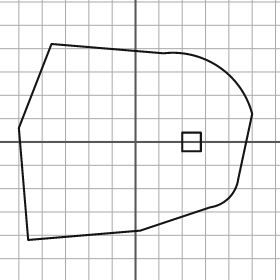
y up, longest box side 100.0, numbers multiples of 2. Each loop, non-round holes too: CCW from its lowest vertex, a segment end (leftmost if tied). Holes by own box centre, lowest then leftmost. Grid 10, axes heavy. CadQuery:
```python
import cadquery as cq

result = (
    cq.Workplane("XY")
    .moveTo(-46.0, -42.0)
    .lineTo(2.0, -38.0)
    .lineTo(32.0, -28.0)
    .threePointArc((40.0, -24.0), (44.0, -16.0))
    .lineTo(50.0, 12.0)
    .threePointArc((36.0, 32.0), (12.0, 38.0))
    .lineTo(-36.0, 42.0)
    .lineTo(-50.0, 6.0)
    .close()
    .moveTo(20.0, -4.0)
    .lineTo(28.0, -4.0)
    .lineTo(28.0, 4.0)
    .lineTo(20.0, 4.0)
    .close()
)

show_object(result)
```